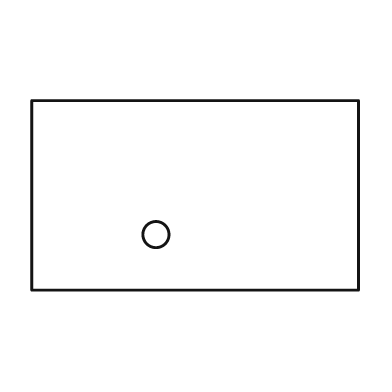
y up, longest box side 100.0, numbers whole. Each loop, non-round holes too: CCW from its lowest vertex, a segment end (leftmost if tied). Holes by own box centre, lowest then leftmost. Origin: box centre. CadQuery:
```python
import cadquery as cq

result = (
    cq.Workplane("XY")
    .moveTo(-50.0, -29.0)
    .lineTo(50.0, -29.0)
    .lineTo(50.0, 29.0)
    .lineTo(-50.0, 29.0)
    .close()
    .moveTo(-12.0, -12.0)
    .circle(4.0)
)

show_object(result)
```